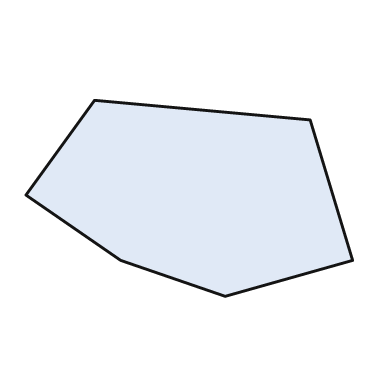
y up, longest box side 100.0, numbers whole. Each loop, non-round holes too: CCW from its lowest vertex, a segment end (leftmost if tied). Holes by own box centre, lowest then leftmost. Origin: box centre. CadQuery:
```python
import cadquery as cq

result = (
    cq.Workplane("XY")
    .moveTo(11.0, -30.0)
    .lineTo(50.0, -19.0)
    .lineTo(37.0, 24.0)
    .lineTo(-29.0, 30.0)
    .lineTo(-50.0, 1.0)
    .lineTo(-21.0, -19.0)
    .close()
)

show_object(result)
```